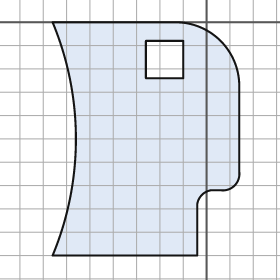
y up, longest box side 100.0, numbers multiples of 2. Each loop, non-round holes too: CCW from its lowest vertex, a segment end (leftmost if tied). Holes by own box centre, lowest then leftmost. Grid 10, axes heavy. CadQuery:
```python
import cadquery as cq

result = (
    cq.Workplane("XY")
    .moveTo(-66.0, -100.0)
    .lineTo(-4.0, -100.0)
    .lineTo(-4.0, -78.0)
    .threePointArc((-2.0, -74.0), (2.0, -72.0))
    .lineTo(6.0, -72.0)
    .threePointArc((12.0, -70.0), (14.0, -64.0))
    .lineTo(14.0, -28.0)
    .threePointArc((6.0, -8.0), (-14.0, 0.0))
    .lineTo(-66.0, 0.0)
    .threePointArc((-56.0, -50.0), (-66.0, -100.0))
    .close()
    .moveTo(-26.0, -24.0)
    .lineTo(-10.0, -24.0)
    .lineTo(-10.0, -8.0)
    .lineTo(-26.0, -8.0)
    .close()
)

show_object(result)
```